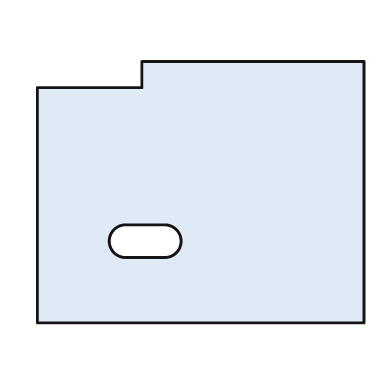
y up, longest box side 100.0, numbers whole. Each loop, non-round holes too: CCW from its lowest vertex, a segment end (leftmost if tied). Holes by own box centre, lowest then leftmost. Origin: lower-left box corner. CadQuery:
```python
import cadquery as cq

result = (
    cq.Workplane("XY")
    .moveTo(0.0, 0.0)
    .lineTo(100.0, 0.0)
    .lineTo(100.0, 80.0)
    .lineTo(32.0, 80.0)
    .lineTo(32.0, 72.0)
    .lineTo(0.0, 72.0)
    .close()
    .moveTo(27.0, 20.0)
    .lineTo(39.0, 20.0)
    .threePointArc((44.0, 25.0), (39.0, 30.0))
    .lineTo(27.0, 30.0)
    .threePointArc((22.0, 25.0), (27.0, 20.0))
    .close()
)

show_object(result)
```